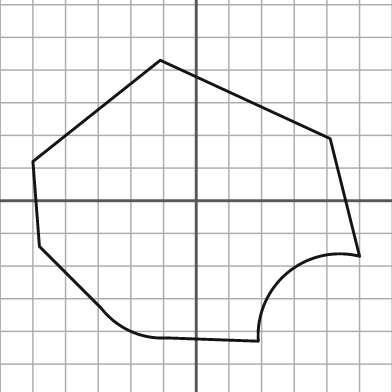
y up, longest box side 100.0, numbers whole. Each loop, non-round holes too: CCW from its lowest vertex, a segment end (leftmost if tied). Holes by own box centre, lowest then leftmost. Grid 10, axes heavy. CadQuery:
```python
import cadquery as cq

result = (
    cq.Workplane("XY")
    .moveTo(19.0, -43.0)
    .threePointArc((28.0, -22.0), (50.0, -17.0))
    .lineTo(41.0, 19.0)
    .lineTo(-11.0, 43.0)
    .lineTo(-50.0, 12.0)
    .lineTo(-48.0, -14.0)
    .lineTo(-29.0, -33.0)
    .threePointArc((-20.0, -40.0), (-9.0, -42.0))
    .close()
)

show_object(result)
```